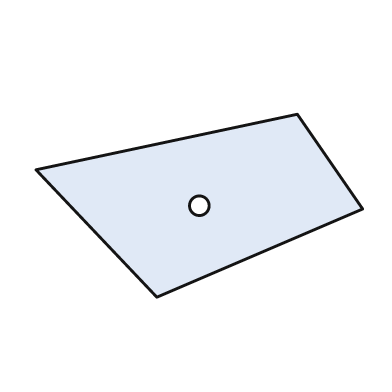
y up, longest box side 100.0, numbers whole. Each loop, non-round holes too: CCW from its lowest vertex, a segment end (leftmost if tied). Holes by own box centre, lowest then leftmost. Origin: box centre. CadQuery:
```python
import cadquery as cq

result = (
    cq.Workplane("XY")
    .moveTo(-13.0, -28.0)
    .lineTo(50.0, -1.0)
    .lineTo(30.0, 28.0)
    .lineTo(-50.0, 11.0)
    .close()
    .moveTo(0.0, 0.0)
    .circle(3.0)
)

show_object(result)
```